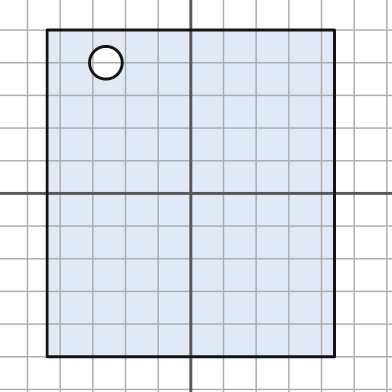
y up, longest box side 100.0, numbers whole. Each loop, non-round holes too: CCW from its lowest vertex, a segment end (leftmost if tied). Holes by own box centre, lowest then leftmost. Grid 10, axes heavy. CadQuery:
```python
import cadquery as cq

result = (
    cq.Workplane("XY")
    .moveTo(-44.0, -50.0)
    .lineTo(44.0, -50.0)
    .lineTo(44.0, 50.0)
    .lineTo(-44.0, 50.0)
    .close()
    .moveTo(-26.0, 40.0)
    .circle(5.0)
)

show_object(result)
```